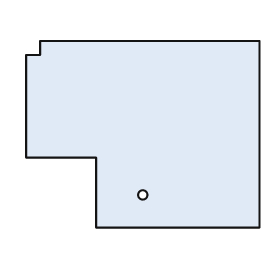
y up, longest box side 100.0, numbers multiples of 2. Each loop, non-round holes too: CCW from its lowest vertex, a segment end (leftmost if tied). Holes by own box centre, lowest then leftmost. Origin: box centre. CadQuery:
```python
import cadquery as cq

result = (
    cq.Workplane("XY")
    .moveTo(-20.0, -40.0)
    .lineTo(50.0, -40.0)
    .lineTo(50.0, 40.0)
    .lineTo(-44.0, 40.0)
    .lineTo(-44.0, 34.0)
    .lineTo(-50.0, 34.0)
    .lineTo(-50.0, -10.0)
    .lineTo(-20.0, -10.0)
    .close()
    .moveTo(0.0, -26.0)
    .circle(2.0)
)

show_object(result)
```